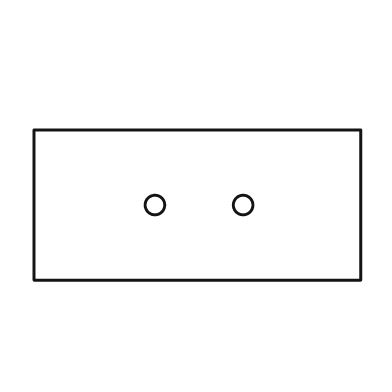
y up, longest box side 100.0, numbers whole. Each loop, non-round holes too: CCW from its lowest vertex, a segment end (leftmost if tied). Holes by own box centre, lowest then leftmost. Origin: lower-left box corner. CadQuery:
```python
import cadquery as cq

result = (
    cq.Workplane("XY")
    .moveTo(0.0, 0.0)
    .lineTo(100.0, 0.0)
    .lineTo(100.0, 46.0)
    .lineTo(0.0, 46.0)
    .close()
    .moveTo(37.0, 23.0)
    .circle(3.0)
    .moveTo(64.0, 23.0)
    .circle(3.0)
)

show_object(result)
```